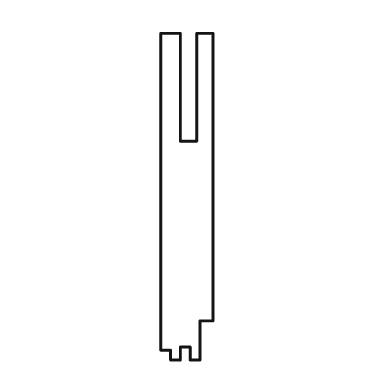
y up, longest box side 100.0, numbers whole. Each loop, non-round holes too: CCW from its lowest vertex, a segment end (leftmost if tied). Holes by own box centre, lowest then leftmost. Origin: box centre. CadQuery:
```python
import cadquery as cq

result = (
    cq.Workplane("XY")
    .moveTo(-5.0, -50.0)
    .lineTo(-2.0, -50.0)
    .lineTo(-2.0, -46.0)
    .lineTo(1.0, -46.0)
    .lineTo(1.0, -50.0)
    .lineTo(4.0, -50.0)
    .lineTo(4.0, -38.0)
    .lineTo(8.0, -38.0)
    .lineTo(8.0, 50.0)
    .lineTo(3.0, 50.0)
    .lineTo(3.0, 17.0)
    .lineTo(-2.0, 17.0)
    .lineTo(-2.0, 50.0)
    .lineTo(-8.0, 50.0)
    .lineTo(-8.0, -47.0)
    .lineTo(-5.0, -47.0)
    .close()
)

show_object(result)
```